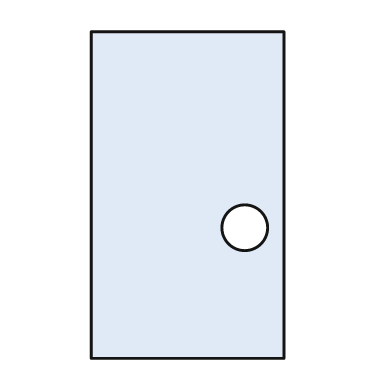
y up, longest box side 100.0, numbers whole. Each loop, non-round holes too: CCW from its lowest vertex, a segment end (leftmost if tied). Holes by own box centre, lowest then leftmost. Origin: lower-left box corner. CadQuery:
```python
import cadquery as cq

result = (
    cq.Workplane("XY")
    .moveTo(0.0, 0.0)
    .lineTo(59.0, 0.0)
    .lineTo(59.0, 100.0)
    .lineTo(0.0, 100.0)
    .close()
    .moveTo(47.0, 40.0)
    .circle(7.0)
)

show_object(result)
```